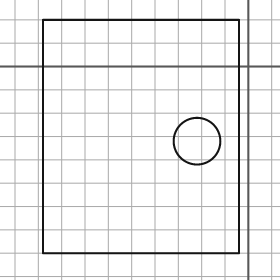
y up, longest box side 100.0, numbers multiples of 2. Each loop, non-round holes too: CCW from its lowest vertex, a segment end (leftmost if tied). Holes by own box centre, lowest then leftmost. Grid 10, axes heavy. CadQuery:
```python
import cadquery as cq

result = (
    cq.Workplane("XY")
    .moveTo(-88.0, -80.0)
    .lineTo(-4.0, -80.0)
    .lineTo(-4.0, 20.0)
    .lineTo(-88.0, 20.0)
    .close()
    .moveTo(-22.0, -32.0)
    .circle(10.0)
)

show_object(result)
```